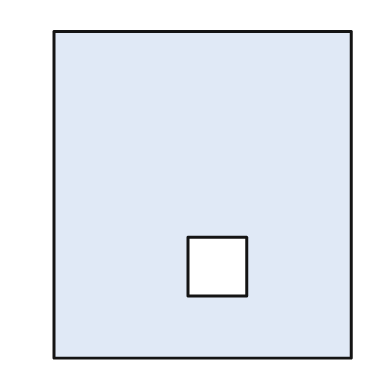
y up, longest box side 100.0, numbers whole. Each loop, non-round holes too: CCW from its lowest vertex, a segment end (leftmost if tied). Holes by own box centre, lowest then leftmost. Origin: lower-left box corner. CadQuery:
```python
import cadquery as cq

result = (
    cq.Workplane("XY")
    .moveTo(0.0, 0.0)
    .lineTo(91.0, 0.0)
    .lineTo(91.0, 100.0)
    .lineTo(0.0, 100.0)
    .close()
    .moveTo(41.0, 19.0)
    .lineTo(59.0, 19.0)
    .lineTo(59.0, 37.0)
    .lineTo(41.0, 37.0)
    .close()
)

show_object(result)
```